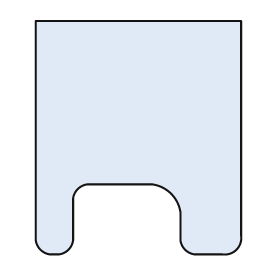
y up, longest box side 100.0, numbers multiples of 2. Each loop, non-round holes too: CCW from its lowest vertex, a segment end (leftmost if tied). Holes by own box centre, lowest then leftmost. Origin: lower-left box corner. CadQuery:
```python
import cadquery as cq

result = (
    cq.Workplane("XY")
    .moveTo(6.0, 0.0)
    .lineTo(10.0, 0.0)
    .threePointArc((14.0, 2.0), (16.0, 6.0))
    .lineTo(16.0, 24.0)
    .threePointArc((18.0, 28.0), (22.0, 30.0))
    .lineTo(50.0, 30.0)
    .threePointArc((58.0, 26.0), (62.0, 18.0))
    .lineTo(62.0, 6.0)
    .threePointArc((64.0, 2.0), (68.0, 0.0))
    .lineTo(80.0, 0.0)
    .threePointArc((86.0, 2.0), (88.0, 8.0))
    .lineTo(88.0, 100.0)
    .lineTo(0.0, 100.0)
    .lineTo(0.0, 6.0)
    .threePointArc((2.0, 2.0), (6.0, 0.0))
    .close()
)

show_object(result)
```